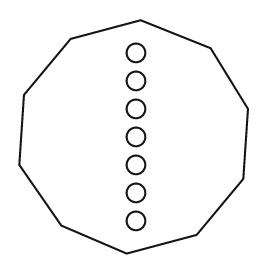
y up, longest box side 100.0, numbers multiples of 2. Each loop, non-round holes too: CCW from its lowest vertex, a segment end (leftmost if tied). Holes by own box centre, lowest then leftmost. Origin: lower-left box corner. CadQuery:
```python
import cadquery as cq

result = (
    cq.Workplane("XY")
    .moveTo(46.0, 0.0)
    .lineTo(76.0, 8.0)
    .lineTo(96.0, 32.0)
    .lineTo(98.0, 62.0)
    .lineTo(82.0, 88.0)
    .lineTo(52.0, 100.0)
    .lineTo(22.0, 92.0)
    .lineTo(2.0, 68.0)
    .lineTo(0.0, 38.0)
    .lineTo(18.0, 12.0)
    .close()
    .moveTo(50.0, 14.0)
    .circle(4.0)
    .moveTo(50.0, 26.0)
    .circle(4.0)
    .moveTo(50.0, 38.0)
    .circle(4.0)
    .moveTo(50.0, 50.0)
    .circle(4.0)
    .moveTo(50.0, 62.0)
    .circle(4.0)
    .moveTo(50.0, 74.0)
    .circle(4.0)
    .moveTo(50.0, 86.0)
    .circle(4.0)
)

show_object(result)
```